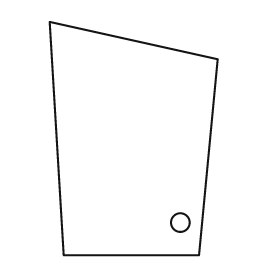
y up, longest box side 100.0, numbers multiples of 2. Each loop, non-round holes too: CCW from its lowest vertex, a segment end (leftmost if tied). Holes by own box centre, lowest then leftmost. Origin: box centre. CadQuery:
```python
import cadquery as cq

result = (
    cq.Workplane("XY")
    .moveTo(-30.0, -50.0)
    .lineTo(28.0, -50.0)
    .lineTo(36.0, 34.0)
    .lineTo(-36.0, 50.0)
    .close()
    .moveTo(20.0, -36.0)
    .circle(4.0)
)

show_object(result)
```